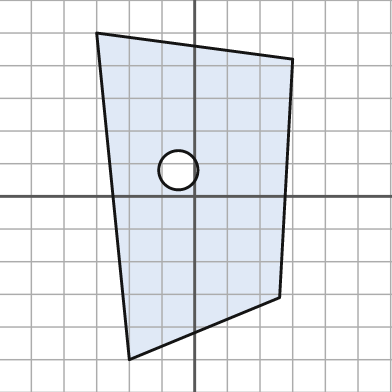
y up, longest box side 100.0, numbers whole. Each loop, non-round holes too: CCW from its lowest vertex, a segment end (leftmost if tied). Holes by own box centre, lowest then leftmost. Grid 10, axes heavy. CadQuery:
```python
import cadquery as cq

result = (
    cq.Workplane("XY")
    .moveTo(-20.0, -50.0)
    .lineTo(26.0, -31.0)
    .lineTo(30.0, 42.0)
    .lineTo(-30.0, 50.0)
    .close()
    .moveTo(-5.0, 8.0)
    .circle(6.0)
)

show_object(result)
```